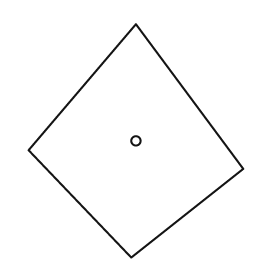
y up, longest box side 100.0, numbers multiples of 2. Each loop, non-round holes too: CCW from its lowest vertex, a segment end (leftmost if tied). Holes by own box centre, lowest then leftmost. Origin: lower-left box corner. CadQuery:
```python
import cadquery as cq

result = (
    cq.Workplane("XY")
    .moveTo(44.0, 0.0)
    .lineTo(92.0, 38.0)
    .lineTo(46.0, 100.0)
    .lineTo(0.0, 46.0)
    .close()
    .moveTo(46.0, 50.0)
    .circle(2.0)
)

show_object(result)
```